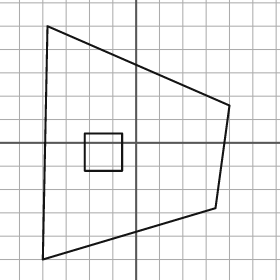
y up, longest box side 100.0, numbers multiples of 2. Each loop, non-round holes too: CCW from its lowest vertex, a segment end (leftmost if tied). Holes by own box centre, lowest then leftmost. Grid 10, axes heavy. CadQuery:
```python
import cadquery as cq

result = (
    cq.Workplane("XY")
    .moveTo(-40.0, -50.0)
    .lineTo(34.0, -28.0)
    .lineTo(40.0, 16.0)
    .lineTo(-38.0, 50.0)
    .close()
    .moveTo(-22.0, -12.0)
    .lineTo(-6.0, -12.0)
    .lineTo(-6.0, 4.0)
    .lineTo(-22.0, 4.0)
    .close()
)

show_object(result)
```